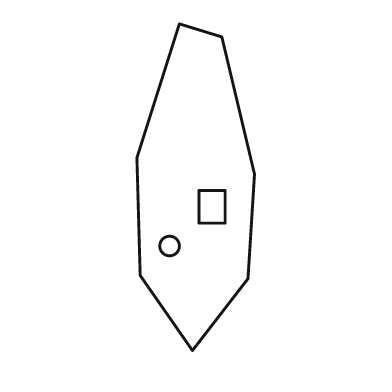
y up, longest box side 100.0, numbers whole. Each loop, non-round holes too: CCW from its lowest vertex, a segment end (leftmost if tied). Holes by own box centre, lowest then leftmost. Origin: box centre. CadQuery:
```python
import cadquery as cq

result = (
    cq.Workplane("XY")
    .moveTo(-1.0, -50.0)
    .lineTo(16.0, -28.0)
    .lineTo(18.0, 4.0)
    .lineTo(8.0, 46.0)
    .lineTo(-5.0, 50.0)
    .lineTo(-18.0, 9.0)
    .lineTo(-17.0, -27.0)
    .close()
    .moveTo(-8.0, -18.0)
    .circle(3.0)
    .moveTo(1.0, -11.0)
    .lineTo(9.0, -11.0)
    .lineTo(9.0, -1.0)
    .lineTo(1.0, -1.0)
    .close()
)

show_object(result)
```